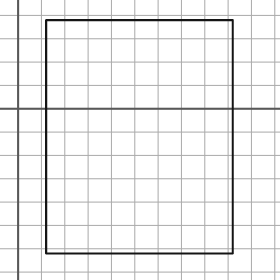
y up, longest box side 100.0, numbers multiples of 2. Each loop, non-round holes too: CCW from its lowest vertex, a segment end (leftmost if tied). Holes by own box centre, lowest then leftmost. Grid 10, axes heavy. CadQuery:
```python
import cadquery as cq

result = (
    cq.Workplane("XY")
    .moveTo(12.0, -62.0)
    .lineTo(92.0, -62.0)
    .lineTo(92.0, 38.0)
    .lineTo(12.0, 38.0)
    .close()
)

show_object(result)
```